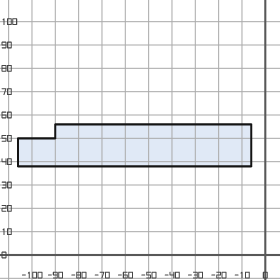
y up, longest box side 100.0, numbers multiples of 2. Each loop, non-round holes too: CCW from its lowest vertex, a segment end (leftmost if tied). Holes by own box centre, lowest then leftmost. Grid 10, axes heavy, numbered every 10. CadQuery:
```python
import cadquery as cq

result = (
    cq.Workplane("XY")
    .moveTo(-106.0, 38.0)
    .lineTo(-6.0, 38.0)
    .lineTo(-6.0, 56.0)
    .lineTo(-90.0, 56.0)
    .lineTo(-90.0, 50.0)
    .lineTo(-106.0, 50.0)
    .close()
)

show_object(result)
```